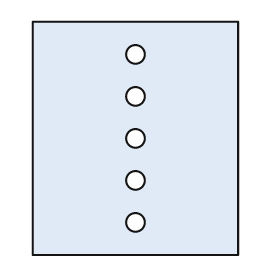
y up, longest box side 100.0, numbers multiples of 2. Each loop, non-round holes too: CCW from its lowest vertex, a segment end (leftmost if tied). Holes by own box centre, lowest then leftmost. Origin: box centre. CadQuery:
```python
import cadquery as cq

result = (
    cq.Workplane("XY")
    .moveTo(-44.0, -50.0)
    .lineTo(44.0, -50.0)
    .lineTo(44.0, 50.0)
    .lineTo(-44.0, 50.0)
    .close()
    .moveTo(0.0, -36.0)
    .circle(4.0)
    .moveTo(0.0, -18.0)
    .circle(4.0)
    .moveTo(0.0, 0.0)
    .circle(4.0)
    .moveTo(0.0, 18.0)
    .circle(4.0)
    .moveTo(0.0, 36.0)
    .circle(4.0)
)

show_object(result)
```